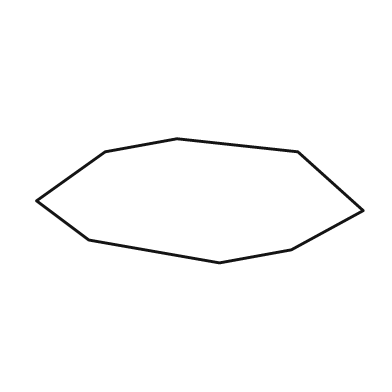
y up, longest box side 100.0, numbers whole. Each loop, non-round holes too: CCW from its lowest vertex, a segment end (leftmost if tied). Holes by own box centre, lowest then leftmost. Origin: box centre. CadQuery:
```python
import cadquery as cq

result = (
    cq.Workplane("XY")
    .moveTo(6.0, -19.0)
    .lineTo(28.0, -15.0)
    .lineTo(50.0, -3.0)
    .lineTo(30.0, 15.0)
    .lineTo(-7.0, 19.0)
    .lineTo(-29.0, 15.0)
    .lineTo(-50.0, 0.0)
    .lineTo(-34.0, -12.0)
    .close()
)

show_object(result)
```